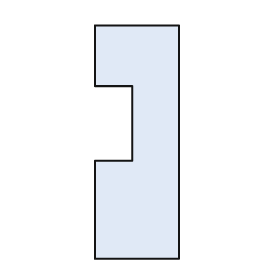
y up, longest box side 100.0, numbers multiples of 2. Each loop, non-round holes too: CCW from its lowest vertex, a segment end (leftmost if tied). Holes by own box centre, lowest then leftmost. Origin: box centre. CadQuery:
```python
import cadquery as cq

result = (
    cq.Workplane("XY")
    .moveTo(-18.0, -50.0)
    .lineTo(18.0, -50.0)
    .lineTo(18.0, 50.0)
    .lineTo(-18.0, 50.0)
    .lineTo(-18.0, 24.0)
    .lineTo(-2.0, 24.0)
    .lineTo(-2.0, -8.0)
    .lineTo(-18.0, -8.0)
    .close()
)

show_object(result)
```